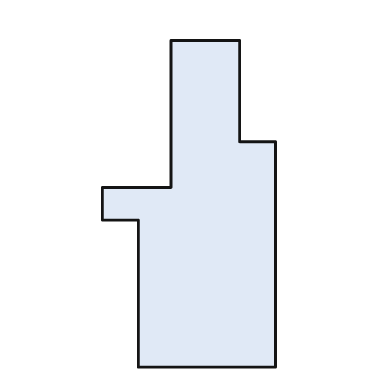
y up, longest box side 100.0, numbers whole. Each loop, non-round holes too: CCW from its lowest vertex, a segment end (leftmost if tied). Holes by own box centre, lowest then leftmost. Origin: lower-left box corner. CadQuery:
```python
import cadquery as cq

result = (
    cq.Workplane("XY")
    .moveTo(11.0, 0.0)
    .lineTo(53.0, 0.0)
    .lineTo(53.0, 69.0)
    .lineTo(42.0, 69.0)
    .lineTo(42.0, 100.0)
    .lineTo(21.0, 100.0)
    .lineTo(21.0, 55.0)
    .lineTo(0.0, 55.0)
    .lineTo(0.0, 45.0)
    .lineTo(11.0, 45.0)
    .close()
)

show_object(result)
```